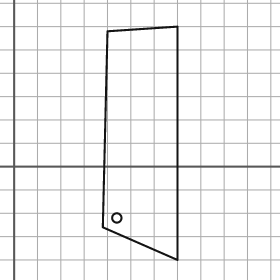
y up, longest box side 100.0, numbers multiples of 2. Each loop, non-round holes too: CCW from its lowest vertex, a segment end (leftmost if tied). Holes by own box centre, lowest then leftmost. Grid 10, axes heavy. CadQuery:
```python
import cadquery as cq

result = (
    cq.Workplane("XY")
    .moveTo(70.0, -40.0)
    .lineTo(70.0, 60.0)
    .lineTo(40.0, 58.0)
    .lineTo(38.0, -26.0)
    .close()
    .moveTo(44.0, -22.0)
    .circle(2.0)
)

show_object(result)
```